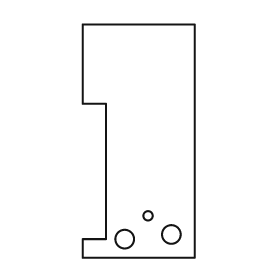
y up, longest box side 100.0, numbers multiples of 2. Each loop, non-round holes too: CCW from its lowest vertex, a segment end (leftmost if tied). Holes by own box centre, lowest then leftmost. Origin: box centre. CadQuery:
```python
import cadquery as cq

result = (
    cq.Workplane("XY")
    .moveTo(-24.0, -50.0)
    .lineTo(24.0, -50.0)
    .lineTo(24.0, 50.0)
    .lineTo(-24.0, 50.0)
    .lineTo(-24.0, 16.0)
    .lineTo(-14.0, 16.0)
    .lineTo(-14.0, -42.0)
    .lineTo(-24.0, -42.0)
    .close()
    .moveTo(-6.0, -42.0)
    .circle(4.0)
    .moveTo(14.0, -40.0)
    .circle(4.0)
    .moveTo(4.0, -32.0)
    .circle(2.0)
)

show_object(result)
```